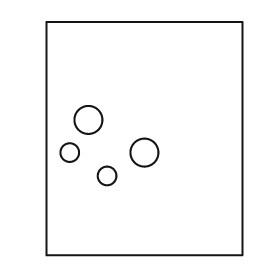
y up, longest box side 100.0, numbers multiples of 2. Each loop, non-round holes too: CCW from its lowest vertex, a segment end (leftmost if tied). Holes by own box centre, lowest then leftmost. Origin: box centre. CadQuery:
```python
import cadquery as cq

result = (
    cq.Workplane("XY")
    .moveTo(-42.0, -50.0)
    .lineTo(42.0, -50.0)
    .lineTo(42.0, 50.0)
    .lineTo(-42.0, 50.0)
    .close()
    .moveTo(-16.0, -16.0)
    .circle(4.0)
    .moveTo(-32.0, -6.0)
    .circle(4.0)
    .moveTo(0.0, -6.0)
    .circle(6.0)
    .moveTo(-24.0, 8.0)
    .circle(6.0)
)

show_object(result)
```